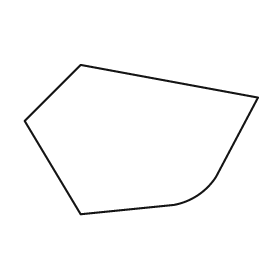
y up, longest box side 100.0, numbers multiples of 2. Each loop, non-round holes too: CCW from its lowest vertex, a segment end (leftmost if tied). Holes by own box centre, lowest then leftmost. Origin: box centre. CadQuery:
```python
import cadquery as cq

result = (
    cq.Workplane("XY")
    .moveTo(-26.0, -32.0)
    .lineTo(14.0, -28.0)
    .threePointArc((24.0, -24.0), (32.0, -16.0))
    .lineTo(50.0, 18.0)
    .lineTo(-26.0, 32.0)
    .lineTo(-50.0, 8.0)
    .close()
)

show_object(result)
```